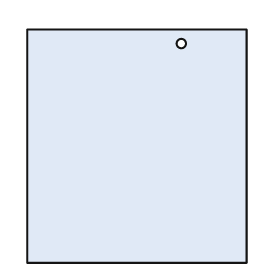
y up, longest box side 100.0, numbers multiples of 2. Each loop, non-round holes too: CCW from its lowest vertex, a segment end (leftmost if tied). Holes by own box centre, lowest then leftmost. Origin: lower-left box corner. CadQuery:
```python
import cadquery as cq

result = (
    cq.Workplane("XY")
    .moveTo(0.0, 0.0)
    .lineTo(94.0, 0.0)
    .lineTo(94.0, 100.0)
    .lineTo(0.0, 100.0)
    .close()
    .moveTo(66.0, 94.0)
    .circle(2.0)
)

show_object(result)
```